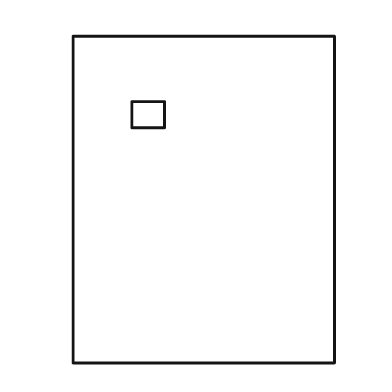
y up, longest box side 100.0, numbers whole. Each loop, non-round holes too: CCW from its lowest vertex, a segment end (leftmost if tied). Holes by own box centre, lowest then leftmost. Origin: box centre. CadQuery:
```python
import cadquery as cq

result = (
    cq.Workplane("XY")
    .moveTo(-40.0, -50.0)
    .lineTo(40.0, -50.0)
    .lineTo(40.0, 50.0)
    .lineTo(-40.0, 50.0)
    .close()
    .moveTo(-22.0, 22.0)
    .lineTo(-12.0, 22.0)
    .lineTo(-12.0, 30.0)
    .lineTo(-22.0, 30.0)
    .close()
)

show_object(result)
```